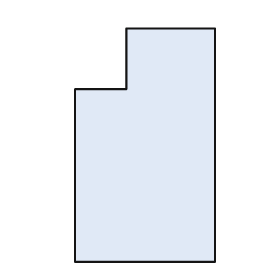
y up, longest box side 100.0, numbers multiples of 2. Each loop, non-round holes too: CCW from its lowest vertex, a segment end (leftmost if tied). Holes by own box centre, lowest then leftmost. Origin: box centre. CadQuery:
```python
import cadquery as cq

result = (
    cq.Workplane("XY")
    .moveTo(-30.0, -50.0)
    .lineTo(30.0, -50.0)
    .lineTo(30.0, 50.0)
    .lineTo(-8.0, 50.0)
    .lineTo(-8.0, 24.0)
    .lineTo(-30.0, 24.0)
    .close()
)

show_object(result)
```